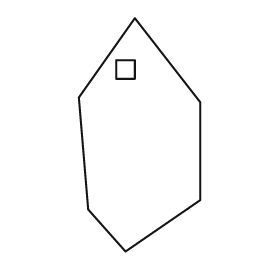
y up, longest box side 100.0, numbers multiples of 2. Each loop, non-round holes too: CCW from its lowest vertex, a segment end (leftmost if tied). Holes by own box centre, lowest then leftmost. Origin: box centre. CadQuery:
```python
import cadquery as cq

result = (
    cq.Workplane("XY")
    .moveTo(-6.0, -50.0)
    .lineTo(26.0, -28.0)
    .lineTo(26.0, 14.0)
    .lineTo(-2.0, 50.0)
    .lineTo(-26.0, 16.0)
    .lineTo(-22.0, -32.0)
    .close()
    .moveTo(-10.0, 24.0)
    .lineTo(-2.0, 24.0)
    .lineTo(-2.0, 32.0)
    .lineTo(-10.0, 32.0)
    .close()
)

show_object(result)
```